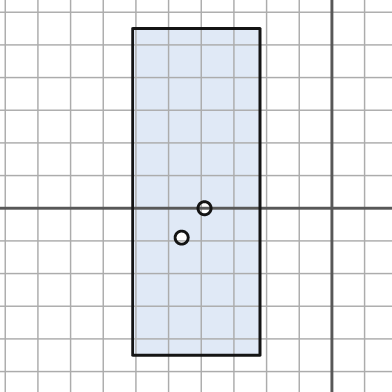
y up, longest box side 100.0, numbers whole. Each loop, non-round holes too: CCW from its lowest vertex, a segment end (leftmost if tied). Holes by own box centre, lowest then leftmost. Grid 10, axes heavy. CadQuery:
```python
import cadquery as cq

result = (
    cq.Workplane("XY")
    .moveTo(-61.0, -45.0)
    .lineTo(-22.0, -45.0)
    .lineTo(-22.0, 55.0)
    .lineTo(-61.0, 55.0)
    .close()
    .moveTo(-46.0, -9.0)
    .circle(2.0)
    .moveTo(-39.0, 0.0)
    .circle(2.0)
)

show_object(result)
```